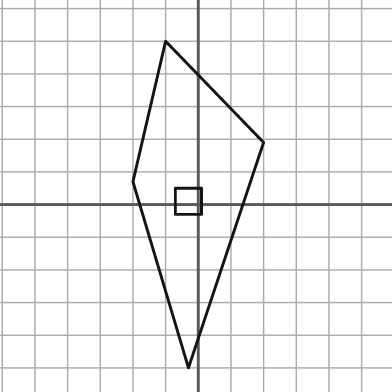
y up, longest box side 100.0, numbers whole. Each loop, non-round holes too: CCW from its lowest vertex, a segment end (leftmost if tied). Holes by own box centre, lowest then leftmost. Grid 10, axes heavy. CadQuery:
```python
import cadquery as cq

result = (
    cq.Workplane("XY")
    .moveTo(-3.0, -50.0)
    .lineTo(20.0, 19.0)
    .lineTo(-10.0, 50.0)
    .lineTo(-20.0, 7.0)
    .close()
    .moveTo(-7.0, -3.0)
    .lineTo(1.0, -3.0)
    .lineTo(1.0, 5.0)
    .lineTo(-7.0, 5.0)
    .close()
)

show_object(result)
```